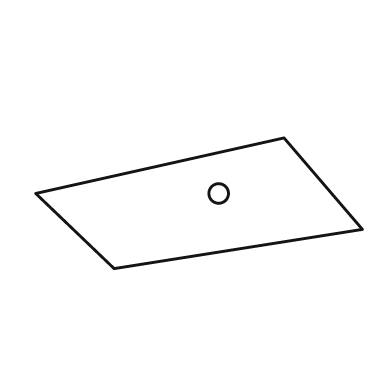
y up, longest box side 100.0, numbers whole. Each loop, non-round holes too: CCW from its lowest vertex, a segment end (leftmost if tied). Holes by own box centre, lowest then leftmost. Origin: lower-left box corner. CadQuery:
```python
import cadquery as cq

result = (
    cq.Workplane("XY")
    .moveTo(24.0, 0.0)
    .lineTo(100.0, 12.0)
    .lineTo(76.0, 40.0)
    .lineTo(0.0, 23.0)
    .close()
    .moveTo(56.0, 23.0)
    .circle(3.0)
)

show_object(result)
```